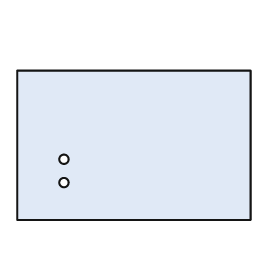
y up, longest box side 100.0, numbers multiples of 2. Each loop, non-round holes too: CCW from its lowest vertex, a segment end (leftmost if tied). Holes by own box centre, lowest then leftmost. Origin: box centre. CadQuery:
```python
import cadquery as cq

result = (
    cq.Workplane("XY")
    .moveTo(-50.0, -32.0)
    .lineTo(50.0, -32.0)
    .lineTo(50.0, 32.0)
    .lineTo(-50.0, 32.0)
    .close()
    .moveTo(-30.0, -16.0)
    .circle(2.0)
    .moveTo(-30.0, -6.0)
    .circle(2.0)
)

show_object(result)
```